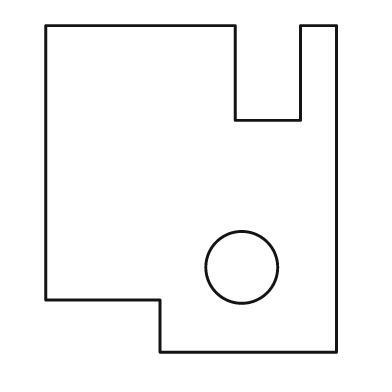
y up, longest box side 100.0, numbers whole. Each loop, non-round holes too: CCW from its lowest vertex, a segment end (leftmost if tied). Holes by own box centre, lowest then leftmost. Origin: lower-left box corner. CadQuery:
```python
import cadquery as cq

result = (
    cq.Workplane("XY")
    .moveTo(35.0, 0.0)
    .lineTo(89.0, 0.0)
    .lineTo(89.0, 100.0)
    .lineTo(78.0, 100.0)
    .lineTo(78.0, 71.0)
    .lineTo(58.0, 71.0)
    .lineTo(58.0, 100.0)
    .lineTo(0.0, 100.0)
    .lineTo(0.0, 16.0)
    .lineTo(35.0, 16.0)
    .close()
    .moveTo(60.0, 26.0)
    .circle(11.0)
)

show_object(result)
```